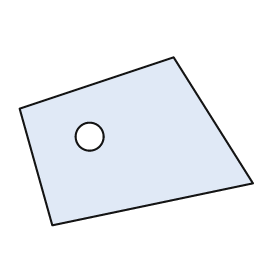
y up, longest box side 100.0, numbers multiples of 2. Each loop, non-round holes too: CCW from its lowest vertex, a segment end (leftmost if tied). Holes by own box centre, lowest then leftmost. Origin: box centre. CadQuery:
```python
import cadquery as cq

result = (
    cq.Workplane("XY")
    .moveTo(-36.0, -36.0)
    .lineTo(50.0, -18.0)
    .lineTo(16.0, 36.0)
    .lineTo(-50.0, 14.0)
    .close()
    .moveTo(-20.0, 2.0)
    .circle(6.0)
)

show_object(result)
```